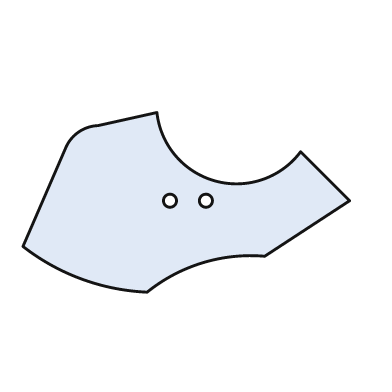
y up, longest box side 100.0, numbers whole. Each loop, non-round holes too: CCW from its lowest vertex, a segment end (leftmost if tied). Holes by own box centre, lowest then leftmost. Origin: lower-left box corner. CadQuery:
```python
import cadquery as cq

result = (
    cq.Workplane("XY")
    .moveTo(38.0, 0.0)
    .threePointArc((55.0, 9.0), (74.0, 11.0))
    .lineTo(100.0, 28.0)
    .lineTo(85.0, 43.0)
    .threePointArc((59.0, 34.0), (41.0, 55.0))
    .lineTo(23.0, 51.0)
    .threePointArc((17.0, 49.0), (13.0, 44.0))
    .lineTo(0.0, 14.0)
    .threePointArc((18.0, 4.0), (38.0, 0.0))
    .close()
    .moveTo(45.0, 28.0)
    .circle(2.0)
    .moveTo(56.0, 28.0)
    .circle(2.0)
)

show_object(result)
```